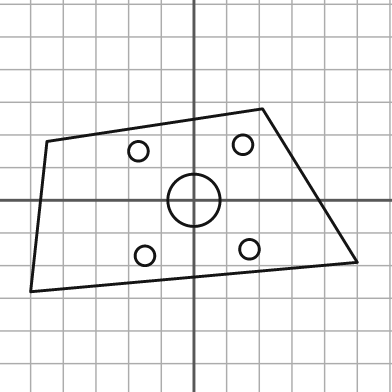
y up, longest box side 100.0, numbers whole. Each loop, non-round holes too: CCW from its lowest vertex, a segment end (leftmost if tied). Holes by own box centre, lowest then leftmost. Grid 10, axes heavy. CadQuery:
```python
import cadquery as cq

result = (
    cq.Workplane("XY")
    .moveTo(-50.0, -28.0)
    .lineTo(50.0, -19.0)
    .lineTo(21.0, 28.0)
    .lineTo(-45.0, 18.0)
    .close()
    .moveTo(-15.0, -17.0)
    .circle(3.0)
    .moveTo(17.0, -15.0)
    .circle(3.0)
    .moveTo(0.0, 0.0)
    .circle(8.0)
    .moveTo(-17.0, 15.0)
    .circle(3.0)
    .moveTo(15.0, 17.0)
    .circle(3.0)
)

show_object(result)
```